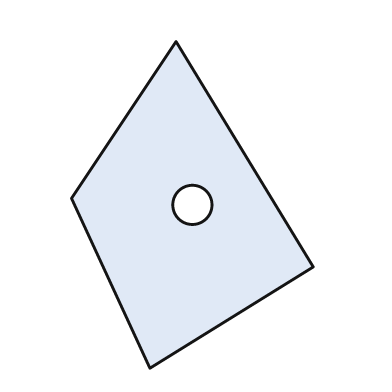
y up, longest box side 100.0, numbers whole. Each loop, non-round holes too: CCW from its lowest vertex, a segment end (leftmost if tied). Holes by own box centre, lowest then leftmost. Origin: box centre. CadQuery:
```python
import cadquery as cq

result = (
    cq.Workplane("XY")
    .moveTo(-13.0, -50.0)
    .lineTo(37.0, -19.0)
    .lineTo(-5.0, 50.0)
    .lineTo(-37.0, 2.0)
    .close()
    .moveTo(0.0, 0.0)
    .circle(6.0)
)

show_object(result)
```